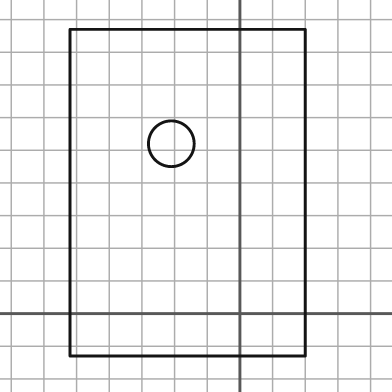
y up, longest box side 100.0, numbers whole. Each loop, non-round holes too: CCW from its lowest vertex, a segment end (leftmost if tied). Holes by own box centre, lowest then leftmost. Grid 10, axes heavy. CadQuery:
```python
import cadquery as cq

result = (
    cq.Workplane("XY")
    .moveTo(-52.0, -13.0)
    .lineTo(20.0, -13.0)
    .lineTo(20.0, 87.0)
    .lineTo(-52.0, 87.0)
    .close()
    .moveTo(-21.0, 52.0)
    .circle(7.0)
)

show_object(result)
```